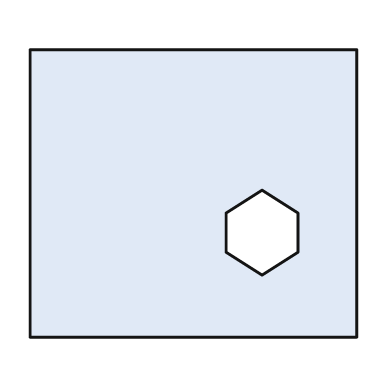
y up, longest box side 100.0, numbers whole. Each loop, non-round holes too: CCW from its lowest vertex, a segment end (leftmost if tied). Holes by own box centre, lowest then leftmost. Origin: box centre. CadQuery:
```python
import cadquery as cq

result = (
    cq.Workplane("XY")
    .moveTo(-50.0, -44.0)
    .lineTo(50.0, -44.0)
    .lineTo(50.0, 44.0)
    .lineTo(-50.0, 44.0)
    .close()
    .moveTo(21.0, -25.0)
    .lineTo(32.0, -18.0)
    .lineTo(32.0, -6.0)
    .lineTo(21.0, 1.0)
    .lineTo(10.0, -6.0)
    .lineTo(10.0, -18.0)
    .close()
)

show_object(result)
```